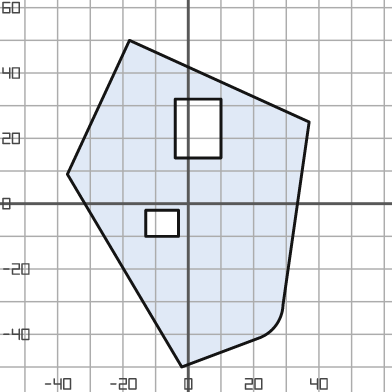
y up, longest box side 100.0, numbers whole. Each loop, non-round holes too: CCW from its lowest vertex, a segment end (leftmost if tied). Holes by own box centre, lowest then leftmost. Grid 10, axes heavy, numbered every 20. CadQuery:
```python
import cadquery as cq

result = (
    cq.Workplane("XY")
    .moveTo(-2.0, -50.0)
    .lineTo(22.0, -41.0)
    .threePointArc((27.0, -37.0), (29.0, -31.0))
    .lineTo(37.0, 25.0)
    .lineTo(-18.0, 50.0)
    .lineTo(-37.0, 9.0)
    .close()
    .moveTo(-13.0, -10.0)
    .lineTo(-3.0, -10.0)
    .lineTo(-3.0, -2.0)
    .lineTo(-13.0, -2.0)
    .close()
    .moveTo(-4.0, 14.0)
    .lineTo(10.0, 14.0)
    .lineTo(10.0, 32.0)
    .lineTo(-4.0, 32.0)
    .close()
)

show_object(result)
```